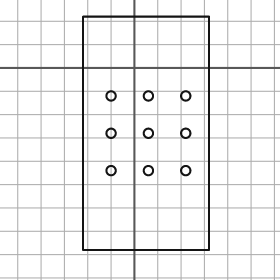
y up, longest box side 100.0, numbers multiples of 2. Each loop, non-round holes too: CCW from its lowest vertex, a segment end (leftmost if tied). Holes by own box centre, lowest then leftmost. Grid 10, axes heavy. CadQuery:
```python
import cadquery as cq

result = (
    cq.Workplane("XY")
    .moveTo(-22.0, -78.0)
    .lineTo(32.0, -78.0)
    .lineTo(32.0, 22.0)
    .lineTo(-22.0, 22.0)
    .close()
    .moveTo(-10.0, -44.0)
    .circle(2.0)
    .moveTo(6.0, -44.0)
    .circle(2.0)
    .moveTo(22.0, -44.0)
    .circle(2.0)
    .moveTo(-10.0, -28.0)
    .circle(2.0)
    .moveTo(6.0, -28.0)
    .circle(2.0)
    .moveTo(22.0, -28.0)
    .circle(2.0)
    .moveTo(-10.0, -12.0)
    .circle(2.0)
    .moveTo(6.0, -12.0)
    .circle(2.0)
    .moveTo(22.0, -12.0)
    .circle(2.0)
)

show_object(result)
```